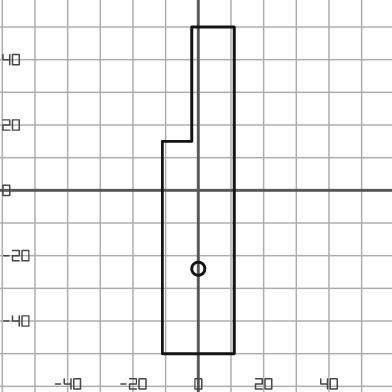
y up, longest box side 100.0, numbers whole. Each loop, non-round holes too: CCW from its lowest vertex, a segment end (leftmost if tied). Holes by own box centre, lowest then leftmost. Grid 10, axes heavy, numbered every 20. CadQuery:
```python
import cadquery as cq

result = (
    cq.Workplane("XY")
    .moveTo(-11.0, -50.0)
    .lineTo(11.0, -50.0)
    .lineTo(11.0, 50.0)
    .lineTo(-2.0, 50.0)
    .lineTo(-2.0, 15.0)
    .lineTo(-11.0, 15.0)
    .close()
    .moveTo(0.0, -24.0)
    .circle(2.0)
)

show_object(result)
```